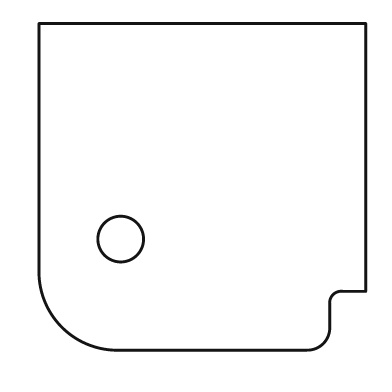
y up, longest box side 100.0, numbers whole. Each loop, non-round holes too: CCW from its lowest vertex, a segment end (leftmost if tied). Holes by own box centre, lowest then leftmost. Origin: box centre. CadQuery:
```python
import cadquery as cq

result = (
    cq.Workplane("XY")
    .moveTo(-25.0, -50.0)
    .lineTo(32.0, -50.0)
    .threePointArc((37.0, -48.0), (39.0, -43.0))
    .lineTo(39.0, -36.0)
    .threePointArc((40.0, -33.0), (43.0, -32.0))
    .lineTo(50.0, -32.0)
    .lineTo(50.0, 50.0)
    .lineTo(-50.0, 50.0)
    .lineTo(-50.0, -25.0)
    .threePointArc((-43.0, -43.0), (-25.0, -50.0))
    .close()
    .moveTo(-25.0, -16.0)
    .circle(7.0)
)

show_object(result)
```